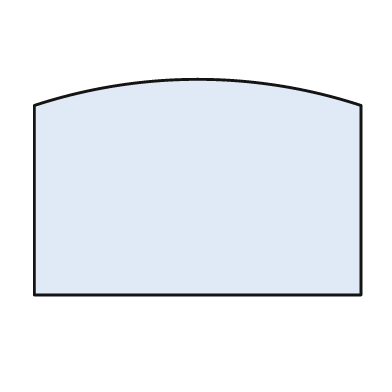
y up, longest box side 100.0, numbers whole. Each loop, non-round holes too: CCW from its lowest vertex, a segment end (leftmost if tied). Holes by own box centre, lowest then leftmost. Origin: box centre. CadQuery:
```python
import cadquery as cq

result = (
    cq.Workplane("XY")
    .moveTo(-50.0, -33.0)
    .lineTo(50.0, -33.0)
    .lineTo(50.0, 25.0)
    .threePointArc((0.0, 33.0), (-50.0, 25.0))
    .close()
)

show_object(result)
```